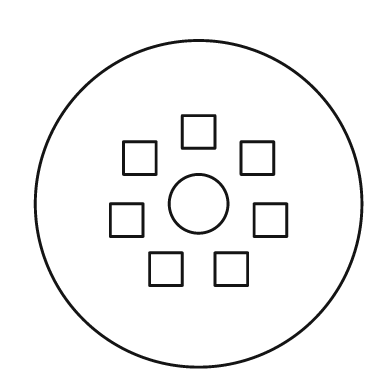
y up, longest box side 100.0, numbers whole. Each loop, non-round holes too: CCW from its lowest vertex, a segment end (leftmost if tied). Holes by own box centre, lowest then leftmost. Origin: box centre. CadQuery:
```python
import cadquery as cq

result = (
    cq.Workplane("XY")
    .moveTo(0.0, 0.0)
    .circle(50.0)
    .moveTo(-15.0, -25.0)
    .lineTo(-5.0, -25.0)
    .lineTo(-5.0, -15.0)
    .lineTo(-15.0, -15.0)
    .close()
    .moveTo(5.0, -25.0)
    .lineTo(15.0, -25.0)
    .lineTo(15.0, -15.0)
    .lineTo(5.0, -15.0)
    .close()
    .moveTo(-27.0, -10.0)
    .lineTo(-17.0, -10.0)
    .lineTo(-17.0, 0.0)
    .lineTo(-27.0, 0.0)
    .close()
    .moveTo(17.0, -10.0)
    .lineTo(27.0, -10.0)
    .lineTo(27.0, 0.0)
    .lineTo(17.0, 0.0)
    .close()
    .moveTo(0.0, 0.0)
    .circle(9.0)
    .moveTo(-23.0, 9.0)
    .lineTo(-13.0, 9.0)
    .lineTo(-13.0, 19.0)
    .lineTo(-23.0, 19.0)
    .close()
    .moveTo(13.0, 9.0)
    .lineTo(23.0, 9.0)
    .lineTo(23.0, 19.0)
    .lineTo(13.0, 19.0)
    .close()
    .moveTo(-5.0, 17.0)
    .lineTo(5.0, 17.0)
    .lineTo(5.0, 27.0)
    .lineTo(-5.0, 27.0)
    .close()
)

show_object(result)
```